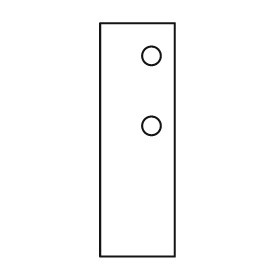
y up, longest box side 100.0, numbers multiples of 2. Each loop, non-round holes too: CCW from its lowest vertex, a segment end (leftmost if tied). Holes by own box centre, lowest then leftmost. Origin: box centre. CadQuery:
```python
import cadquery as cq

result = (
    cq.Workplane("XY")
    .moveTo(-16.0, -50.0)
    .lineTo(16.0, -50.0)
    .lineTo(16.0, 50.0)
    .lineTo(-16.0, 50.0)
    .close()
    .moveTo(6.0, 6.0)
    .circle(4.0)
    .moveTo(6.0, 36.0)
    .circle(4.0)
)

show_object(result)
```